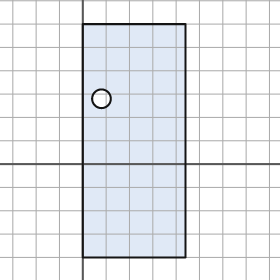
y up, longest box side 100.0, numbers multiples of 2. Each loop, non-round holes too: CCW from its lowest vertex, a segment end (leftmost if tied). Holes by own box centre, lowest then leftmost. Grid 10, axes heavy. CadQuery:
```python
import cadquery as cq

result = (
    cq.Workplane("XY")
    .moveTo(0.0, -40.0)
    .lineTo(44.0, -40.0)
    .lineTo(44.0, 60.0)
    .lineTo(0.0, 60.0)
    .close()
    .moveTo(8.0, 28.0)
    .circle(4.0)
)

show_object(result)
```